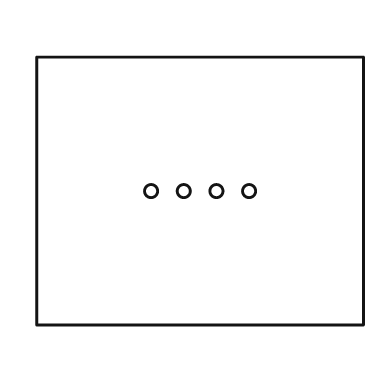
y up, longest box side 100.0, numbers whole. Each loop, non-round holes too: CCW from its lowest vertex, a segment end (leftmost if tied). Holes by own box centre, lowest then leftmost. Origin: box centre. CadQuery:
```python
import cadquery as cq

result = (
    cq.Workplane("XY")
    .moveTo(-50.0, -41.0)
    .lineTo(50.0, -41.0)
    .lineTo(50.0, 41.0)
    .lineTo(-50.0, 41.0)
    .close()
    .moveTo(-15.0, 0.0)
    .circle(2.0)
    .moveTo(-5.0, 0.0)
    .circle(2.0)
    .moveTo(5.0, 0.0)
    .circle(2.0)
    .moveTo(15.0, 0.0)
    .circle(2.0)
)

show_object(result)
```